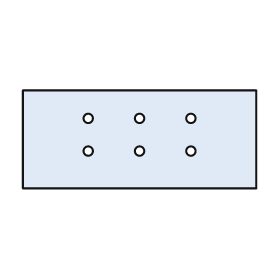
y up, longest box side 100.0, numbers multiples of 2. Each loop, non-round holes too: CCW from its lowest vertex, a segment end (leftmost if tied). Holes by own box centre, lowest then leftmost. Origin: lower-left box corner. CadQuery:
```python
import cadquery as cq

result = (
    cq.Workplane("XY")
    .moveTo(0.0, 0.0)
    .lineTo(100.0, 0.0)
    .lineTo(100.0, 42.0)
    .lineTo(0.0, 42.0)
    .close()
    .moveTo(28.0, 16.0)
    .circle(2.0)
    .moveTo(50.0, 16.0)
    .circle(2.0)
    .moveTo(72.0, 16.0)
    .circle(2.0)
    .moveTo(28.0, 30.0)
    .circle(2.0)
    .moveTo(50.0, 30.0)
    .circle(2.0)
    .moveTo(72.0, 30.0)
    .circle(2.0)
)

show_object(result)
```